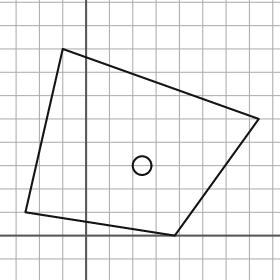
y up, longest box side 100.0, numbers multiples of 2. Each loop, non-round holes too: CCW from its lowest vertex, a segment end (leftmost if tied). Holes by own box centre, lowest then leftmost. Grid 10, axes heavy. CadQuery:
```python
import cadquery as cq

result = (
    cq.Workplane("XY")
    .moveTo(38.0, 0.0)
    .lineTo(74.0, 50.0)
    .lineTo(-10.0, 80.0)
    .lineTo(-26.0, 10.0)
    .close()
    .moveTo(24.0, 30.0)
    .circle(4.0)
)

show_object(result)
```